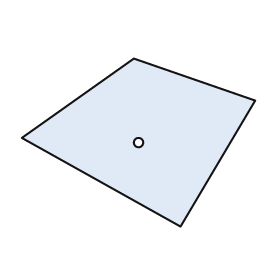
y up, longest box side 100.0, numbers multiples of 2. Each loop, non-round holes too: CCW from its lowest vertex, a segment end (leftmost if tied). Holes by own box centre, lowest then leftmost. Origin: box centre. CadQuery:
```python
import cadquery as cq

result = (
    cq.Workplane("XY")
    .moveTo(18.0, -36.0)
    .lineTo(50.0, 18.0)
    .lineTo(-2.0, 36.0)
    .lineTo(-50.0, 2.0)
    .close()
    .moveTo(0.0, 0.0)
    .circle(2.0)
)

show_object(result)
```